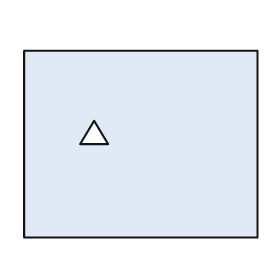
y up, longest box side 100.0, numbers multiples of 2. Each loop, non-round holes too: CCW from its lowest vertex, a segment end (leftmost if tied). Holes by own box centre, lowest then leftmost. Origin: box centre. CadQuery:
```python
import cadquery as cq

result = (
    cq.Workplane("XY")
    .moveTo(-50.0, -40.0)
    .lineTo(50.0, -40.0)
    .lineTo(50.0, 40.0)
    .lineTo(-50.0, 40.0)
    .close()
    .moveTo(-26.0, 0.0)
    .lineTo(-14.0, 0.0)
    .lineTo(-20.0, 10.0)
    .close()
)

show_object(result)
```